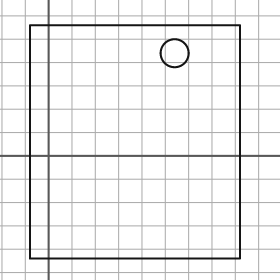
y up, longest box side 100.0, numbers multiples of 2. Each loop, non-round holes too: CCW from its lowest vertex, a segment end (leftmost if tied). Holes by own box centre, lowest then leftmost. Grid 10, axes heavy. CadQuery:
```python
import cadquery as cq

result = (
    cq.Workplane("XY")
    .moveTo(-8.0, -44.0)
    .lineTo(82.0, -44.0)
    .lineTo(82.0, 56.0)
    .lineTo(-8.0, 56.0)
    .close()
    .moveTo(54.0, 44.0)
    .circle(6.0)
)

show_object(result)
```